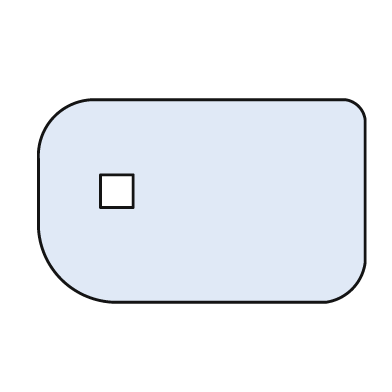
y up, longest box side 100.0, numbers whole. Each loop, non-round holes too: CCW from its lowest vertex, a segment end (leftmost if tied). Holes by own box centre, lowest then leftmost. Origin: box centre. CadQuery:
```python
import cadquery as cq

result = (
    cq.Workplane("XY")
    .moveTo(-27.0, -31.0)
    .lineTo(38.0, -31.0)
    .threePointArc((46.0, -27.0), (50.0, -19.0))
    .lineTo(50.0, 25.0)
    .threePointArc((48.0, 29.0), (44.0, 31.0))
    .lineTo(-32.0, 31.0)
    .threePointArc((-45.0, 26.0), (-50.0, 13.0))
    .lineTo(-50.0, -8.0)
    .threePointArc((-43.0, -24.0), (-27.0, -31.0))
    .close()
    .moveTo(-31.0, -2.0)
    .lineTo(-21.0, -2.0)
    .lineTo(-21.0, 8.0)
    .lineTo(-31.0, 8.0)
    .close()
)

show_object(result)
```